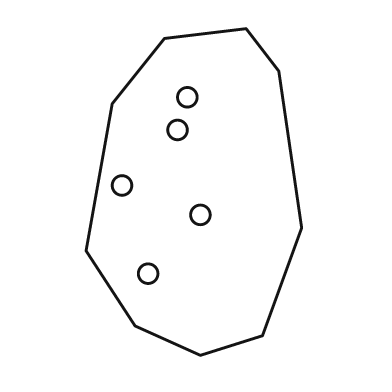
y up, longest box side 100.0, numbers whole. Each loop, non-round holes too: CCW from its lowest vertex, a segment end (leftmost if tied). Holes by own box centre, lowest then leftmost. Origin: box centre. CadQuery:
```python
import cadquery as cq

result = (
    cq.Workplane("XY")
    .moveTo(2.0, -50.0)
    .lineTo(21.0, -44.0)
    .lineTo(33.0, -11.0)
    .lineTo(26.0, 37.0)
    .lineTo(16.0, 50.0)
    .lineTo(-9.0, 47.0)
    .lineTo(-25.0, 27.0)
    .lineTo(-33.0, -18.0)
    .lineTo(-18.0, -41.0)
    .close()
    .moveTo(-14.0, -25.0)
    .circle(3.0)
    .moveTo(2.0, -7.0)
    .circle(3.0)
    .moveTo(-22.0, 2.0)
    .circle(3.0)
    .moveTo(-5.0, 19.0)
    .circle(3.0)
    .moveTo(-2.0, 29.0)
    .circle(3.0)
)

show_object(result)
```